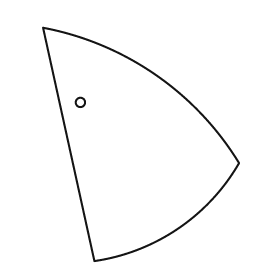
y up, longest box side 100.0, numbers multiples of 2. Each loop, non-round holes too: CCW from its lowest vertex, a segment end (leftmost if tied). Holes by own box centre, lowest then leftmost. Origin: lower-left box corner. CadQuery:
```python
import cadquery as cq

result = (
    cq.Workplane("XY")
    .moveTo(22.0, 0.0)
    .threePointArc((58.0, 14.0), (84.0, 42.0))
    .threePointArc((48.0, 80.0), (0.0, 100.0))
    .close()
    .moveTo(16.0, 68.0)
    .circle(2.0)
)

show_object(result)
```